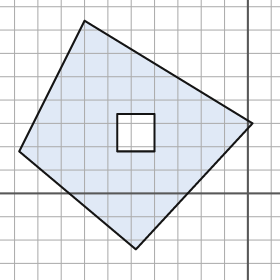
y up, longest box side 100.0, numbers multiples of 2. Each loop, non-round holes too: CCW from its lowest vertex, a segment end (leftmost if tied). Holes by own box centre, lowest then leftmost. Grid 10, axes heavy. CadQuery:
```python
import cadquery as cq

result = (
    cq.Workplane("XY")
    .moveTo(-48.0, -24.0)
    .lineTo(2.0, 30.0)
    .lineTo(-70.0, 74.0)
    .lineTo(-98.0, 18.0)
    .close()
    .moveTo(-56.0, 18.0)
    .lineTo(-40.0, 18.0)
    .lineTo(-40.0, 34.0)
    .lineTo(-56.0, 34.0)
    .close()
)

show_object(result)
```